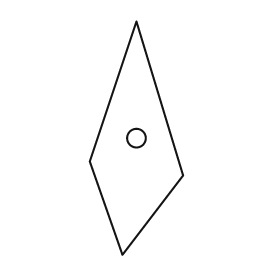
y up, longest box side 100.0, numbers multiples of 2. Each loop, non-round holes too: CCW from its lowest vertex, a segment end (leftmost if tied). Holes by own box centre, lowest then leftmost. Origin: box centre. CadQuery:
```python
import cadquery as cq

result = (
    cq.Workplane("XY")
    .moveTo(-6.0, -50.0)
    .lineTo(20.0, -16.0)
    .lineTo(0.0, 50.0)
    .lineTo(-20.0, -10.0)
    .close()
    .moveTo(0.0, 0.0)
    .circle(4.0)
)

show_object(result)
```